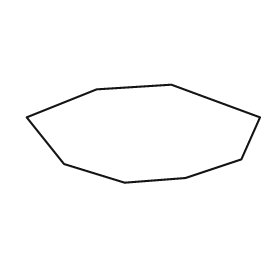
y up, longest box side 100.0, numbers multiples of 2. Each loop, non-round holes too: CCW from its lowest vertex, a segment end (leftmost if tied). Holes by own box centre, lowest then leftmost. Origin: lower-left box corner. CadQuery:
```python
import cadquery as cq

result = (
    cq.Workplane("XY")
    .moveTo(42.0, 0.0)
    .lineTo(68.0, 2.0)
    .lineTo(92.0, 10.0)
    .lineTo(100.0, 28.0)
    .lineTo(62.0, 42.0)
    .lineTo(30.0, 40.0)
    .lineTo(0.0, 28.0)
    .lineTo(16.0, 8.0)
    .close()
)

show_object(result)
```